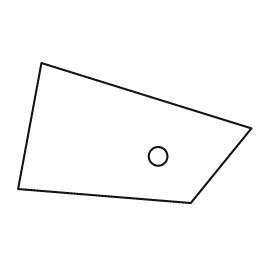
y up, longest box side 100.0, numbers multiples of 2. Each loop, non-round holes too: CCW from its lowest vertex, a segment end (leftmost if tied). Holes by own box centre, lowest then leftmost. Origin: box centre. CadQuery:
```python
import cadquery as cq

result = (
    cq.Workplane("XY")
    .moveTo(24.0, -30.0)
    .lineTo(50.0, 2.0)
    .lineTo(-40.0, 30.0)
    .lineTo(-50.0, -24.0)
    .close()
    .moveTo(10.0, -10.0)
    .circle(4.0)
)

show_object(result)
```